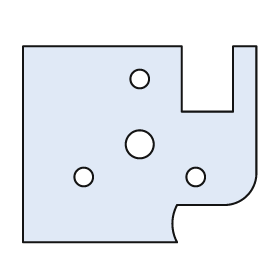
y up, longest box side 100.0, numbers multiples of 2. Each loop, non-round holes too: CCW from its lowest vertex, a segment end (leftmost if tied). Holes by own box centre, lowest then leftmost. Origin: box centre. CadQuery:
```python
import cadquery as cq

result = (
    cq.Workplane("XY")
    .moveTo(-50.0, -42.0)
    .lineTo(16.0, -42.0)
    .threePointArc((14.0, -34.0), (16.0, -26.0))
    .lineTo(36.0, -26.0)
    .threePointArc((46.0, -22.0), (50.0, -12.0))
    .lineTo(50.0, 42.0)
    .lineTo(40.0, 42.0)
    .lineTo(40.0, 14.0)
    .lineTo(18.0, 14.0)
    .lineTo(18.0, 42.0)
    .lineTo(-50.0, 42.0)
    .close()
    .moveTo(-24.0, -14.0)
    .circle(4.0)
    .moveTo(24.0, -14.0)
    .circle(4.0)
    .moveTo(0.0, 0.0)
    .circle(6.0)
    .moveTo(0.0, 28.0)
    .circle(4.0)
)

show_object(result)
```